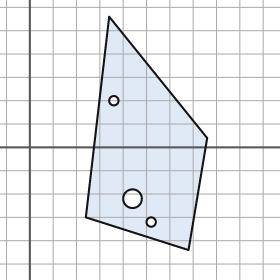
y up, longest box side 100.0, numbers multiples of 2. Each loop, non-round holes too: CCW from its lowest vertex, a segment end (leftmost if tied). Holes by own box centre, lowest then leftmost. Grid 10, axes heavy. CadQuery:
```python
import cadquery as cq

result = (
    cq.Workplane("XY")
    .moveTo(68.0, -44.0)
    .lineTo(76.0, 4.0)
    .lineTo(34.0, 56.0)
    .lineTo(24.0, -30.0)
    .close()
    .moveTo(52.0, -32.0)
    .circle(2.0)
    .moveTo(44.0, -22.0)
    .circle(4.0)
    .moveTo(36.0, 20.0)
    .circle(2.0)
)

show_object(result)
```